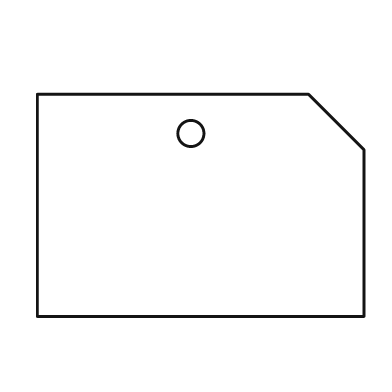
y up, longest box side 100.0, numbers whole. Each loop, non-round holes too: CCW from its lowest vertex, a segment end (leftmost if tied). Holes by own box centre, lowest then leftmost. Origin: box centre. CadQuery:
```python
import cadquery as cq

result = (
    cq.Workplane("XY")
    .moveTo(-50.0, -34.0)
    .lineTo(50.0, -34.0)
    .lineTo(50.0, 17.0)
    .lineTo(33.0, 34.0)
    .lineTo(-50.0, 34.0)
    .close()
    .moveTo(-3.0, 22.0)
    .circle(4.0)
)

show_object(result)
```